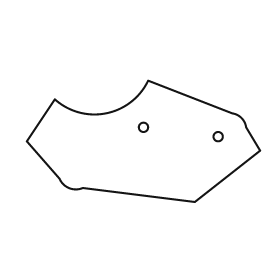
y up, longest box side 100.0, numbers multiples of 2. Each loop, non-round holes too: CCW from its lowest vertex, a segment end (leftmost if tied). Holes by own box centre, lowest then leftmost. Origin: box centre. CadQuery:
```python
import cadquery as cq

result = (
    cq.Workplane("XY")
    .moveTo(22.0, -26.0)
    .lineTo(50.0, -4.0)
    .lineTo(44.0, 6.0)
    .threePointArc((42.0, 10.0), (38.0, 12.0))
    .lineTo(2.0, 26.0)
    .threePointArc((-16.0, 12.0), (-38.0, 18.0))
    .lineTo(-50.0, 0.0)
    .lineTo(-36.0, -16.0)
    .threePointArc((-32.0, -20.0), (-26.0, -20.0))
    .close()
    .moveTo(32.0, 2.0)
    .circle(2.0)
    .moveTo(0.0, 6.0)
    .circle(2.0)
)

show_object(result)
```